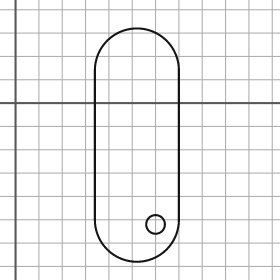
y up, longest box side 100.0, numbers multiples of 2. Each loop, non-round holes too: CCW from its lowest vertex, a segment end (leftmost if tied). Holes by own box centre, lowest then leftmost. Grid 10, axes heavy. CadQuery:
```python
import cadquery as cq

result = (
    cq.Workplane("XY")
    .moveTo(34.0, -50.0)
    .threePointArc((52.0, -68.0), (70.0, -50.0))
    .lineTo(70.0, 14.0)
    .threePointArc((52.0, 32.0), (34.0, 14.0))
    .close()
    .moveTo(60.0, -52.0)
    .circle(4.0)
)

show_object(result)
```